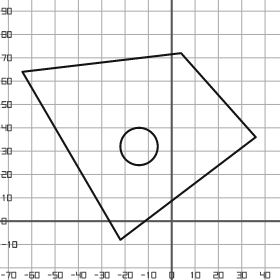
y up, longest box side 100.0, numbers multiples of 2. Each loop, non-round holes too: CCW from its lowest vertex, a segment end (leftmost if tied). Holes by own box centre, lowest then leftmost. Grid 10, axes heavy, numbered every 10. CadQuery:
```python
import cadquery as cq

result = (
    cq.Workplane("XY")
    .moveTo(-22.0, -8.0)
    .lineTo(36.0, 36.0)
    .lineTo(4.0, 72.0)
    .lineTo(-64.0, 64.0)
    .close()
    .moveTo(-14.0, 32.0)
    .circle(8.0)
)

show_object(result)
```